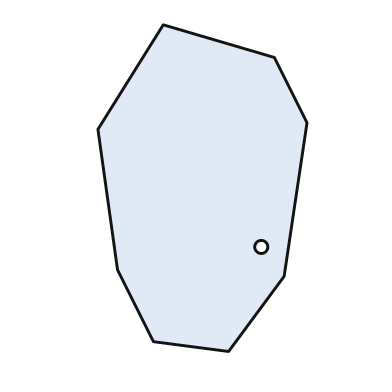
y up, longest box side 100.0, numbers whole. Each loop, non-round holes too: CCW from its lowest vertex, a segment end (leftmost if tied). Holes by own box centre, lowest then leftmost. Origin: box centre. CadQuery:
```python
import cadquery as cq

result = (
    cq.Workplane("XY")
    .moveTo(8.0, -50.0)
    .lineTo(25.0, -27.0)
    .lineTo(32.0, 20.0)
    .lineTo(22.0, 40.0)
    .lineTo(-12.0, 50.0)
    .lineTo(-32.0, 18.0)
    .lineTo(-26.0, -25.0)
    .lineTo(-15.0, -47.0)
    .close()
    .moveTo(18.0, -18.0)
    .circle(2.0)
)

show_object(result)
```